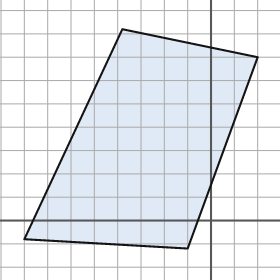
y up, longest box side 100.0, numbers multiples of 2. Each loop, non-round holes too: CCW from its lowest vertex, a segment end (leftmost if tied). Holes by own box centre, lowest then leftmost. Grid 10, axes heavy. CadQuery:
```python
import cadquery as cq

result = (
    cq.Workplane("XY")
    .moveTo(-10.0, -12.0)
    .lineTo(20.0, 70.0)
    .lineTo(-38.0, 82.0)
    .lineTo(-80.0, -8.0)
    .close()
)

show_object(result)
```